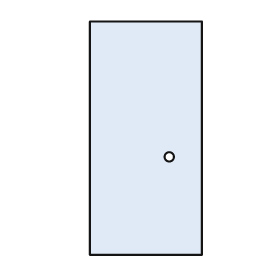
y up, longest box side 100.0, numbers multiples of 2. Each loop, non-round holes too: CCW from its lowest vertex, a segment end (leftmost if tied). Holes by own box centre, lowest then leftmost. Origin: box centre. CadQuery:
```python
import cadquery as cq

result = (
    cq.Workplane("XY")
    .moveTo(-24.0, -50.0)
    .lineTo(24.0, -50.0)
    .lineTo(24.0, 50.0)
    .lineTo(-24.0, 50.0)
    .close()
    .moveTo(10.0, -8.0)
    .circle(2.0)
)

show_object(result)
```